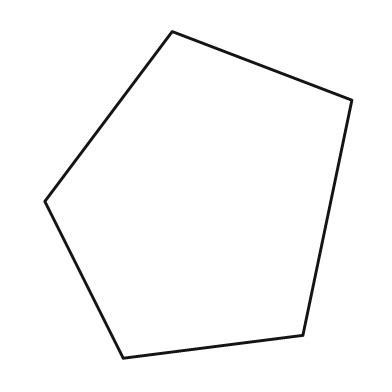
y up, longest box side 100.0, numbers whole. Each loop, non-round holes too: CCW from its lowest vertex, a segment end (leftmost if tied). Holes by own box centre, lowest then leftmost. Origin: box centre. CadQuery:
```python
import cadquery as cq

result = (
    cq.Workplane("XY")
    .moveTo(-23.0, -50.0)
    .lineTo(32.0, -43.0)
    .lineTo(47.0, 29.0)
    .lineTo(-8.0, 50.0)
    .lineTo(-47.0, -2.0)
    .close()
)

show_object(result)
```